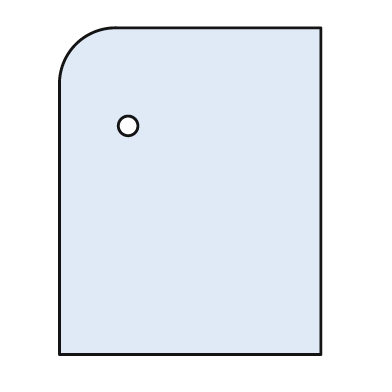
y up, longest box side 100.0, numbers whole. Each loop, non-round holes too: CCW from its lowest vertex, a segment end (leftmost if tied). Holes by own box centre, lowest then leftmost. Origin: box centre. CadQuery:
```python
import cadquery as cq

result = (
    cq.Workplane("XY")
    .moveTo(-40.0, -50.0)
    .lineTo(40.0, -50.0)
    .lineTo(40.0, 50.0)
    .lineTo(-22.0, 50.0)
    .threePointArc((-35.0, 45.0), (-40.0, 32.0))
    .close()
    .moveTo(-19.0, 20.0)
    .circle(3.0)
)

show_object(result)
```